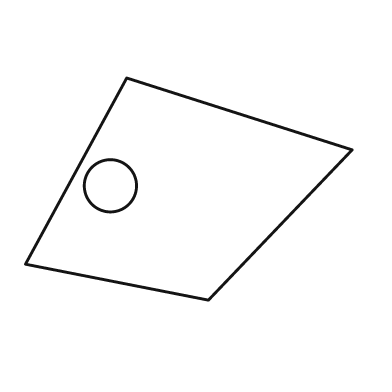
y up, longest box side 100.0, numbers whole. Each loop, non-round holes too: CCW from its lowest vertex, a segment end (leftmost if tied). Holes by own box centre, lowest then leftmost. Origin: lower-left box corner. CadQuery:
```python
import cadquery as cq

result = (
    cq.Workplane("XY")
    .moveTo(56.0, 0.0)
    .lineTo(100.0, 46.0)
    .lineTo(31.0, 68.0)
    .lineTo(0.0, 11.0)
    .close()
    .moveTo(26.0, 35.0)
    .circle(8.0)
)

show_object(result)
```